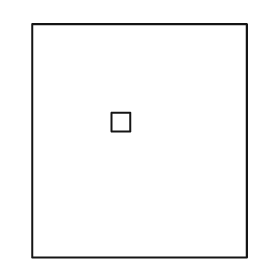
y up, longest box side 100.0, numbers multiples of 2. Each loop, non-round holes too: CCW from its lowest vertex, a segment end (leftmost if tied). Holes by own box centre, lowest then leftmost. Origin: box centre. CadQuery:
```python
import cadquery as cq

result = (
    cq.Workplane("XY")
    .moveTo(-46.0, -50.0)
    .lineTo(46.0, -50.0)
    .lineTo(46.0, 50.0)
    .lineTo(-46.0, 50.0)
    .close()
    .moveTo(-12.0, 4.0)
    .lineTo(-4.0, 4.0)
    .lineTo(-4.0, 12.0)
    .lineTo(-12.0, 12.0)
    .close()
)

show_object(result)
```